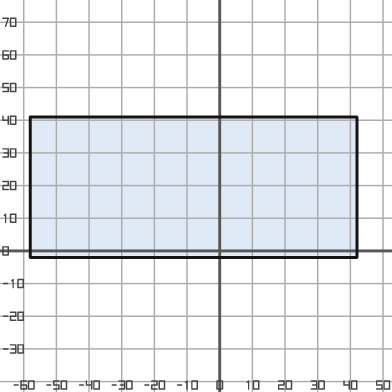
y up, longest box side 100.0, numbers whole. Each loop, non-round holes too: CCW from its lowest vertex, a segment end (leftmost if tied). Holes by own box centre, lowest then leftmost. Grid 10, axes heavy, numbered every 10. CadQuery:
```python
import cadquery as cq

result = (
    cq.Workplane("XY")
    .moveTo(-58.0, -2.0)
    .lineTo(42.0, -2.0)
    .lineTo(42.0, 41.0)
    .lineTo(-58.0, 41.0)
    .close()
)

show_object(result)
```